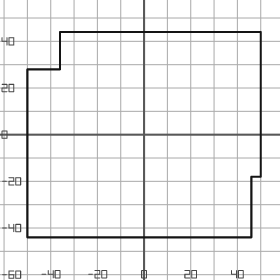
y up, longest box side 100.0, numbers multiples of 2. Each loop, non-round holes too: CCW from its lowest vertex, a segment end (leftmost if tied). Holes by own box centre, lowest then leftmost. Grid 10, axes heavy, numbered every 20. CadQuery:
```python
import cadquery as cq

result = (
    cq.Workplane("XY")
    .moveTo(-50.0, -44.0)
    .lineTo(46.0, -44.0)
    .lineTo(46.0, -18.0)
    .lineTo(50.0, -18.0)
    .lineTo(50.0, 44.0)
    .lineTo(-36.0, 44.0)
    .lineTo(-36.0, 28.0)
    .lineTo(-50.0, 28.0)
    .close()
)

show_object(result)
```